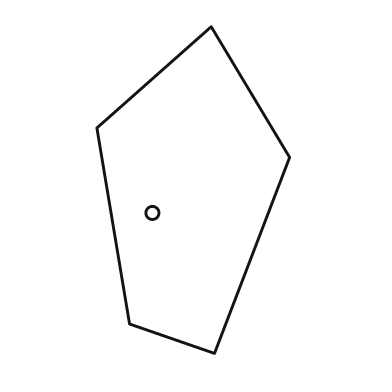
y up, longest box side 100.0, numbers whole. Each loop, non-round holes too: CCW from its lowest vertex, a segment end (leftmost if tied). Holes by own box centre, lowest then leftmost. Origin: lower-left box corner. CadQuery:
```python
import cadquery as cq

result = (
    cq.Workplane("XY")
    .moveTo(36.0, 0.0)
    .lineTo(59.0, 60.0)
    .lineTo(35.0, 100.0)
    .lineTo(0.0, 69.0)
    .lineTo(10.0, 9.0)
    .close()
    .moveTo(17.0, 43.0)
    .circle(2.0)
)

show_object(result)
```